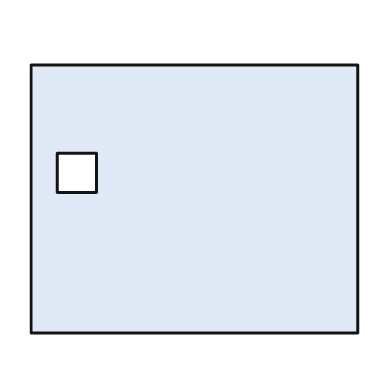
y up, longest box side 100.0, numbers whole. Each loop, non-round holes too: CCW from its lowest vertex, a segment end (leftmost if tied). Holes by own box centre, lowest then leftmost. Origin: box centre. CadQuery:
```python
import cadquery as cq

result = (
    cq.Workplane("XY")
    .moveTo(-50.0, -41.0)
    .lineTo(50.0, -41.0)
    .lineTo(50.0, 41.0)
    .lineTo(-50.0, 41.0)
    .close()
    .moveTo(-42.0, 2.0)
    .lineTo(-30.0, 2.0)
    .lineTo(-30.0, 14.0)
    .lineTo(-42.0, 14.0)
    .close()
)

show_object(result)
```